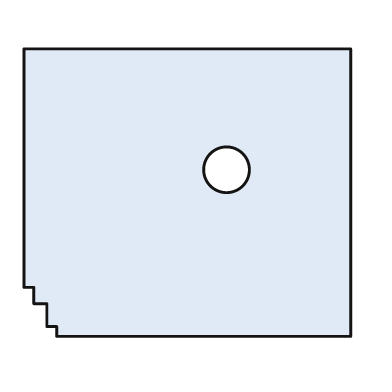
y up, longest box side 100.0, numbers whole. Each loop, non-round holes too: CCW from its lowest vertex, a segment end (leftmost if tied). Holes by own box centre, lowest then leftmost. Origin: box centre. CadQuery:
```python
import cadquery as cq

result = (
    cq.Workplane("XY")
    .moveTo(-40.0, -44.0)
    .lineTo(50.0, -44.0)
    .lineTo(50.0, 44.0)
    .lineTo(-50.0, 44.0)
    .lineTo(-50.0, -29.0)
    .lineTo(-47.0, -29.0)
    .lineTo(-47.0, -34.0)
    .lineTo(-43.0, -34.0)
    .lineTo(-43.0, -41.0)
    .lineTo(-40.0, -41.0)
    .close()
    .moveTo(12.0, 7.0)
    .circle(7.0)
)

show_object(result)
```